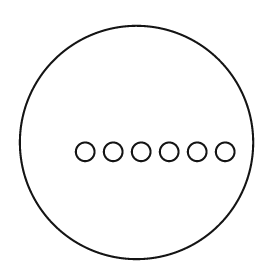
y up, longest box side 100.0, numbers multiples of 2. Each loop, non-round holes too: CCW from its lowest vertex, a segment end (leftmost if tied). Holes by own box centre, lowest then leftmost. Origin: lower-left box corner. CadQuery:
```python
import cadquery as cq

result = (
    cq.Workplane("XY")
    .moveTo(50.0, 50.0)
    .circle(50.0)
    .moveTo(28.0, 46.0)
    .circle(4.0)
    .moveTo(40.0, 46.0)
    .circle(4.0)
    .moveTo(52.0, 46.0)
    .circle(4.0)
    .moveTo(64.0, 46.0)
    .circle(4.0)
    .moveTo(76.0, 46.0)
    .circle(4.0)
    .moveTo(88.0, 46.0)
    .circle(4.0)
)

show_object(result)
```